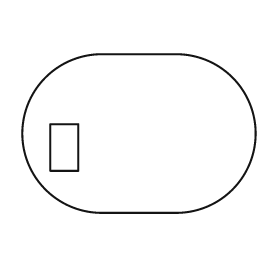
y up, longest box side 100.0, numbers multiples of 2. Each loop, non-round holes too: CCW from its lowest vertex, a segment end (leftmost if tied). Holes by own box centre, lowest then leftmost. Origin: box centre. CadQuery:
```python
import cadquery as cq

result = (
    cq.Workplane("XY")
    .moveTo(-16.0, -34.0)
    .lineTo(16.0, -34.0)
    .threePointArc((50.0, 0.0), (16.0, 34.0))
    .lineTo(-16.0, 34.0)
    .threePointArc((-50.0, 0.0), (-16.0, -34.0))
    .close()
    .moveTo(-38.0, -16.0)
    .lineTo(-26.0, -16.0)
    .lineTo(-26.0, 4.0)
    .lineTo(-38.0, 4.0)
    .close()
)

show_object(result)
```